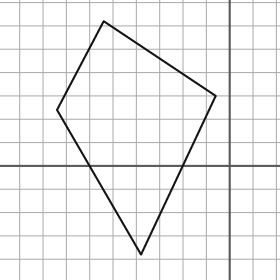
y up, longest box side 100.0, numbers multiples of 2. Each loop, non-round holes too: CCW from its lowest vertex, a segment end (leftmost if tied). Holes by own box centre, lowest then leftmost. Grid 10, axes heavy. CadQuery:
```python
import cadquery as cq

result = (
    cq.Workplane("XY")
    .moveTo(-38.0, -38.0)
    .lineTo(-6.0, 30.0)
    .lineTo(-54.0, 62.0)
    .lineTo(-74.0, 24.0)
    .close()
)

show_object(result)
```